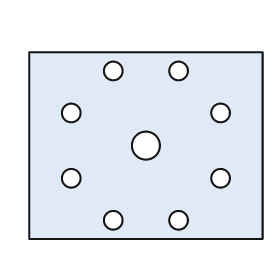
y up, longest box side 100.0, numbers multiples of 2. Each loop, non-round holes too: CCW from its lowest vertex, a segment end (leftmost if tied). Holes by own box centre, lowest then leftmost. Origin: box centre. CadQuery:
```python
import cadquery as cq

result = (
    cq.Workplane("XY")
    .moveTo(-50.0, -40.0)
    .lineTo(50.0, -40.0)
    .lineTo(50.0, 40.0)
    .lineTo(-50.0, 40.0)
    .close()
    .moveTo(-14.0, -32.0)
    .circle(4.0)
    .moveTo(14.0, -32.0)
    .circle(4.0)
    .moveTo(-32.0, -14.0)
    .circle(4.0)
    .moveTo(32.0, -14.0)
    .circle(4.0)
    .moveTo(0.0, 0.0)
    .circle(6.0)
    .moveTo(-32.0, 14.0)
    .circle(4.0)
    .moveTo(32.0, 14.0)
    .circle(4.0)
    .moveTo(-14.0, 32.0)
    .circle(4.0)
    .moveTo(14.0, 32.0)
    .circle(4.0)
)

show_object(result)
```